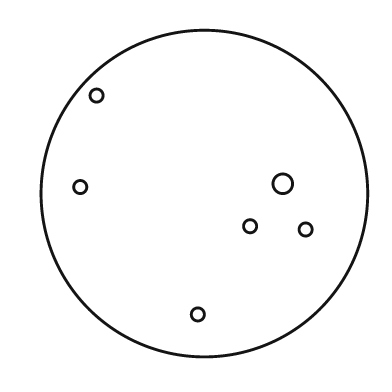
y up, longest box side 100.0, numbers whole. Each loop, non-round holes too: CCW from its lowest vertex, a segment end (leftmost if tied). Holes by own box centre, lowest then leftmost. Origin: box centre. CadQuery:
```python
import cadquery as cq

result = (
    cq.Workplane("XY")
    .moveTo(0.0, 0.0)
    .circle(50.0)
    .moveTo(-2.0, -37.0)
    .circle(2.0)
    .moveTo(31.0, -11.0)
    .circle(2.0)
    .moveTo(14.0, -10.0)
    .circle(2.0)
    .moveTo(-38.0, 2.0)
    .circle(2.0)
    .moveTo(24.0, 3.0)
    .circle(3.0)
    .moveTo(-33.0, 30.0)
    .circle(2.0)
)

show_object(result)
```